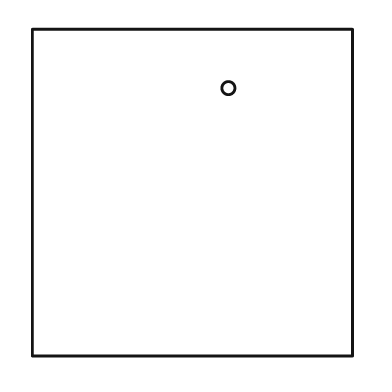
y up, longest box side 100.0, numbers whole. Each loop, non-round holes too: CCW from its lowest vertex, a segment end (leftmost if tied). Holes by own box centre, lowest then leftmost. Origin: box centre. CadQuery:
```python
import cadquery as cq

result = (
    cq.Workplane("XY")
    .moveTo(-49.0, -50.0)
    .lineTo(49.0, -50.0)
    .lineTo(49.0, 50.0)
    .lineTo(-49.0, 50.0)
    .close()
    .moveTo(11.0, 32.0)
    .circle(2.0)
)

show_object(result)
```